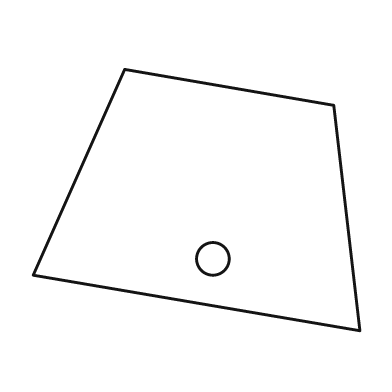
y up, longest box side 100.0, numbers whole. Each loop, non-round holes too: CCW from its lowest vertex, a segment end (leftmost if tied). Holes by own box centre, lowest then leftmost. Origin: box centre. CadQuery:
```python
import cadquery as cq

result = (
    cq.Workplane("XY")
    .moveTo(50.0, -40.0)
    .lineTo(42.0, 29.0)
    .lineTo(-22.0, 40.0)
    .lineTo(-50.0, -23.0)
    .close()
    .moveTo(5.0, -18.0)
    .circle(5.0)
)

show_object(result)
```